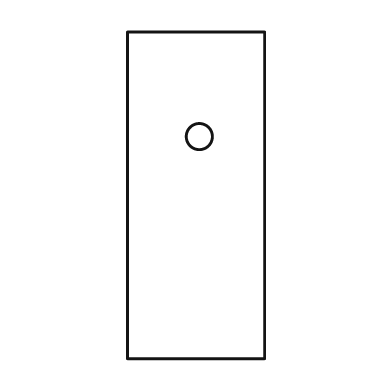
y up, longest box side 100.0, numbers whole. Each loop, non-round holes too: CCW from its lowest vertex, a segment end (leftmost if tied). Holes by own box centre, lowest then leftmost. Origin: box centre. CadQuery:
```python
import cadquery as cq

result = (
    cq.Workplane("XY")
    .moveTo(-21.0, -50.0)
    .lineTo(21.0, -50.0)
    .lineTo(21.0, 50.0)
    .lineTo(-21.0, 50.0)
    .close()
    .moveTo(1.0, 18.0)
    .circle(4.0)
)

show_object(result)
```